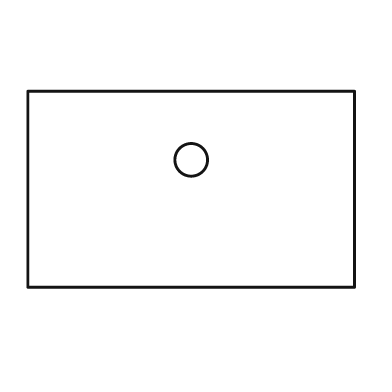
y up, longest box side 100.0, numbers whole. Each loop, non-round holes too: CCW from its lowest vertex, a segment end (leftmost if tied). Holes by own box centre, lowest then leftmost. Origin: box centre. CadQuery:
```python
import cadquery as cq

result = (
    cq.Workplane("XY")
    .moveTo(-50.0, -30.0)
    .lineTo(50.0, -30.0)
    .lineTo(50.0, 30.0)
    .lineTo(-50.0, 30.0)
    .close()
    .moveTo(0.0, 9.0)
    .circle(5.0)
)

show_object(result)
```